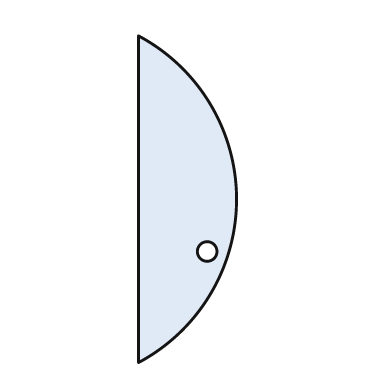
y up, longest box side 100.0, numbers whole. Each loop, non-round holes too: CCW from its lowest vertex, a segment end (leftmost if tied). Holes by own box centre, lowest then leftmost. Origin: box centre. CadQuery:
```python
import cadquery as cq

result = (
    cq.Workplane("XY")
    .moveTo(-15.0, -50.0)
    .threePointArc((15.0, 0.0), (-15.0, 50.0))
    .close()
    .moveTo(6.0, -16.0)
    .circle(3.0)
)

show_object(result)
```